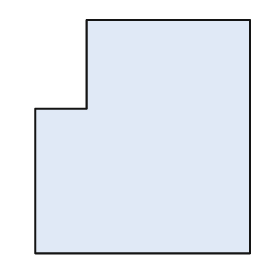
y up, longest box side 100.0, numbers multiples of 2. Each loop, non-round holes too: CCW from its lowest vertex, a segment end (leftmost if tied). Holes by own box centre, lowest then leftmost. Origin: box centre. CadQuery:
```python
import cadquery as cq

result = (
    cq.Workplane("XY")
    .moveTo(-46.0, -50.0)
    .lineTo(46.0, -50.0)
    .lineTo(46.0, 50.0)
    .lineTo(-24.0, 50.0)
    .lineTo(-24.0, 12.0)
    .lineTo(-46.0, 12.0)
    .close()
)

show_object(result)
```